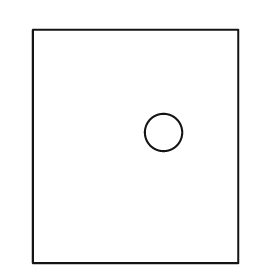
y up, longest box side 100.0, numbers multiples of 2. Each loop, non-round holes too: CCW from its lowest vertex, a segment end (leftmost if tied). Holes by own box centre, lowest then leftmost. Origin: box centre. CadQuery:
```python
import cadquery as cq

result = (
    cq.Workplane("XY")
    .moveTo(-44.0, -50.0)
    .lineTo(44.0, -50.0)
    .lineTo(44.0, 50.0)
    .lineTo(-44.0, 50.0)
    .close()
    .moveTo(12.0, 6.0)
    .circle(8.0)
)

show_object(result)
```